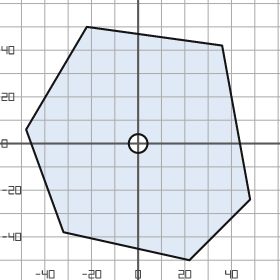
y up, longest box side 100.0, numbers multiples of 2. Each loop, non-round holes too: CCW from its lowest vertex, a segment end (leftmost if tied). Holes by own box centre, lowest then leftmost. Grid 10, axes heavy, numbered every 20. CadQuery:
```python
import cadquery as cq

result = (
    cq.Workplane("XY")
    .moveTo(22.0, -50.0)
    .lineTo(48.0, -24.0)
    .lineTo(36.0, 42.0)
    .lineTo(-22.0, 50.0)
    .lineTo(-48.0, 6.0)
    .lineTo(-32.0, -38.0)
    .close()
    .moveTo(0.0, 0.0)
    .circle(4.0)
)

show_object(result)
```